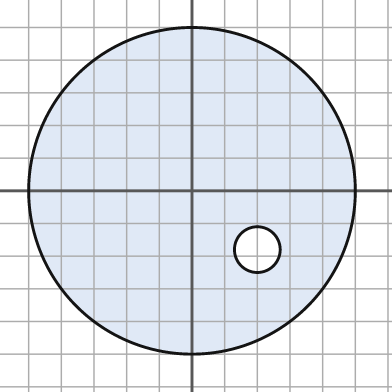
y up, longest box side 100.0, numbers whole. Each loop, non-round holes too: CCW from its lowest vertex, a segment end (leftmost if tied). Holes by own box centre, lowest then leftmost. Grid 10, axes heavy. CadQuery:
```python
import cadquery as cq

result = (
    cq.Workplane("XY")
    .moveTo(0.0, 0.0)
    .circle(50.0)
    .moveTo(20.0, -18.0)
    .circle(7.0)
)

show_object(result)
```